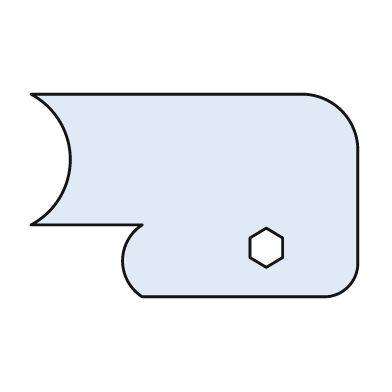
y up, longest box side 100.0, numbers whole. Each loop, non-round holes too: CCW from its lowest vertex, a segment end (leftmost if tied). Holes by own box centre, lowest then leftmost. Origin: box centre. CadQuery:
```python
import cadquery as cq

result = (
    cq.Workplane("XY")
    .moveTo(-16.0, -31.0)
    .lineTo(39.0, -31.0)
    .threePointArc((47.0, -28.0), (50.0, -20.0))
    .lineTo(50.0, 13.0)
    .threePointArc((45.0, 26.0), (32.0, 31.0))
    .lineTo(-50.0, 31.0)
    .threePointArc((-38.0, 11.0), (-50.0, -9.0))
    .lineTo(-16.0, -9.0)
    .threePointArc((-22.0, -20.0), (-16.0, -31.0))
    .close()
    .moveTo(22.0, -22.0)
    .lineTo(27.0, -19.0)
    .lineTo(27.0, -13.0)
    .lineTo(22.0, -10.0)
    .lineTo(17.0, -13.0)
    .lineTo(17.0, -19.0)
    .close()
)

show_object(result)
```